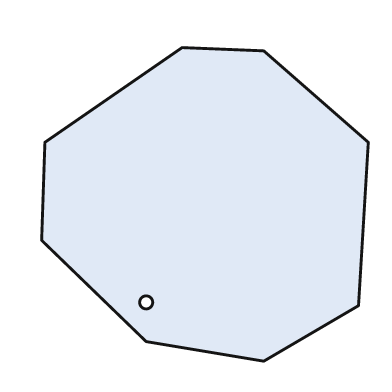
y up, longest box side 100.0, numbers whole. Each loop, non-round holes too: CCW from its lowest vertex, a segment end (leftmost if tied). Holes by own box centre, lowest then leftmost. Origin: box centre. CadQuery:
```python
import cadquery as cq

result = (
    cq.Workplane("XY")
    .moveTo(18.0, -48.0)
    .lineTo(47.0, -31.0)
    .lineTo(50.0, 19.0)
    .lineTo(18.0, 47.0)
    .lineTo(-7.0, 48.0)
    .lineTo(-49.0, 19.0)
    .lineTo(-50.0, -11.0)
    .lineTo(-18.0, -42.0)
    .close()
    .moveTo(-18.0, -30.0)
    .circle(2.0)
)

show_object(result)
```